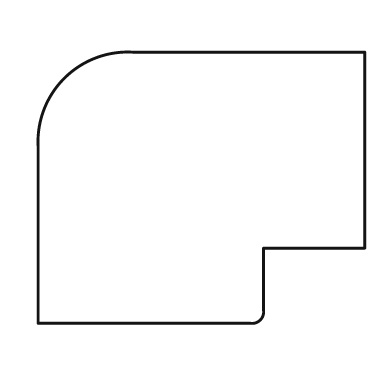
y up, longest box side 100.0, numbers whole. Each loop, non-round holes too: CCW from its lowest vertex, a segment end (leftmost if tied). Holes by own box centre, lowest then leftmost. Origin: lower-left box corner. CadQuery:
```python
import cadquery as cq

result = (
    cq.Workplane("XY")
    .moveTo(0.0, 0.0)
    .lineTo(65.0, 0.0)
    .threePointArc((68.0, 1.0), (69.0, 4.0))
    .lineTo(69.0, 23.0)
    .lineTo(100.0, 23.0)
    .lineTo(100.0, 83.0)
    .lineTo(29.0, 83.0)
    .threePointArc((8.0, 75.0), (0.0, 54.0))
    .close()
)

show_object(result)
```